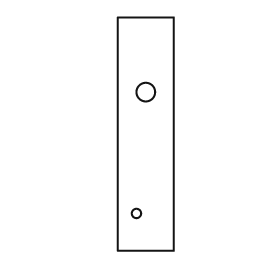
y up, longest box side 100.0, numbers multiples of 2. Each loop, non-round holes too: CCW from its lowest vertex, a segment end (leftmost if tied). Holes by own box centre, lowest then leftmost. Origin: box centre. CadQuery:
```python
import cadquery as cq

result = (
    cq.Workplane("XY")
    .moveTo(-12.0, -50.0)
    .lineTo(12.0, -50.0)
    .lineTo(12.0, 50.0)
    .lineTo(-12.0, 50.0)
    .close()
    .moveTo(-4.0, -34.0)
    .circle(2.0)
    .moveTo(0.0, 18.0)
    .circle(4.0)
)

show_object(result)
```